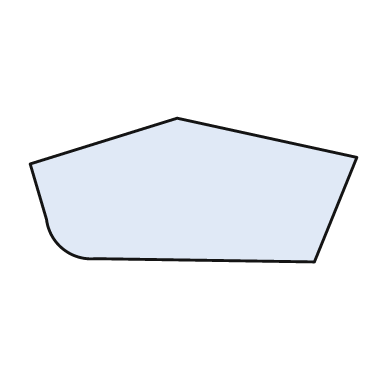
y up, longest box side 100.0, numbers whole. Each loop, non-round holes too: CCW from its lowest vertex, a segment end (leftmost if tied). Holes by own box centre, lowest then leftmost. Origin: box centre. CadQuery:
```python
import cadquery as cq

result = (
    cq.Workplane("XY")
    .moveTo(37.0, -22.0)
    .lineTo(50.0, 10.0)
    .lineTo(-5.0, 22.0)
    .lineTo(-50.0, 8.0)
    .lineTo(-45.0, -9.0)
    .threePointArc((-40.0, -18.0), (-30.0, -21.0))
    .close()
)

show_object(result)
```